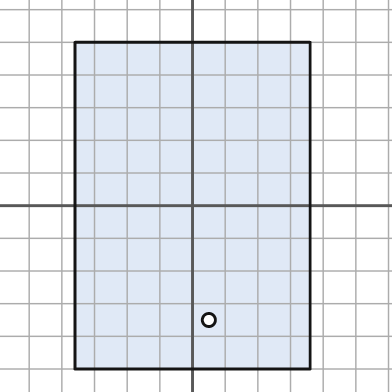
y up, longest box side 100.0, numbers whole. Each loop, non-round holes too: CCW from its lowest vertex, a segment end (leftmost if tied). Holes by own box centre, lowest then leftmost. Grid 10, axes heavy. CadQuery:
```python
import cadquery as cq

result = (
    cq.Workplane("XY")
    .moveTo(-36.0, -50.0)
    .lineTo(36.0, -50.0)
    .lineTo(36.0, 50.0)
    .lineTo(-36.0, 50.0)
    .close()
    .moveTo(5.0, -35.0)
    .circle(2.0)
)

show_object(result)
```